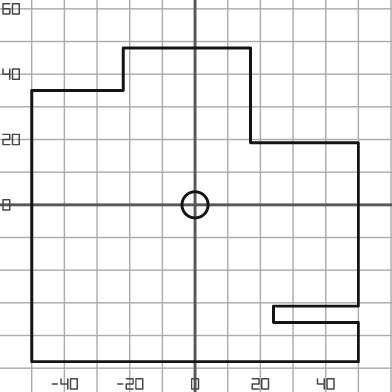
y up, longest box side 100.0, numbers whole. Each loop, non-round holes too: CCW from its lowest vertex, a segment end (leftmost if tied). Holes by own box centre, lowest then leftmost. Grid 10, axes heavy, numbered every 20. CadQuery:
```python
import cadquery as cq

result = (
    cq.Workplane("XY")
    .moveTo(-50.0, -48.0)
    .lineTo(50.0, -48.0)
    .lineTo(50.0, -36.0)
    .lineTo(24.0, -36.0)
    .lineTo(24.0, -31.0)
    .lineTo(50.0, -31.0)
    .lineTo(50.0, 19.0)
    .lineTo(17.0, 19.0)
    .lineTo(17.0, 48.0)
    .lineTo(-22.0, 48.0)
    .lineTo(-22.0, 35.0)
    .lineTo(-50.0, 35.0)
    .close()
    .moveTo(0.0, 0.0)
    .circle(4.0)
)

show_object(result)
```